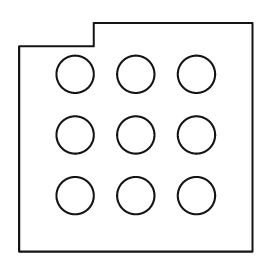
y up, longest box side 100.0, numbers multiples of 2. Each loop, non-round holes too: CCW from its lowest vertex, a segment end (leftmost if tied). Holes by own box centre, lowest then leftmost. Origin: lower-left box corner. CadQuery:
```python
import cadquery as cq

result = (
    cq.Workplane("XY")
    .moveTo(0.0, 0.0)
    .lineTo(100.0, 0.0)
    .lineTo(100.0, 98.0)
    .lineTo(32.0, 98.0)
    .lineTo(32.0, 88.0)
    .lineTo(0.0, 88.0)
    .close()
    .moveTo(24.0, 24.0)
    .circle(8.0)
    .moveTo(50.0, 24.0)
    .circle(8.0)
    .moveTo(76.0, 24.0)
    .circle(8.0)
    .moveTo(24.0, 50.0)
    .circle(8.0)
    .moveTo(50.0, 50.0)
    .circle(8.0)
    .moveTo(76.0, 50.0)
    .circle(8.0)
    .moveTo(24.0, 76.0)
    .circle(8.0)
    .moveTo(50.0, 76.0)
    .circle(8.0)
    .moveTo(76.0, 76.0)
    .circle(8.0)
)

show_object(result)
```